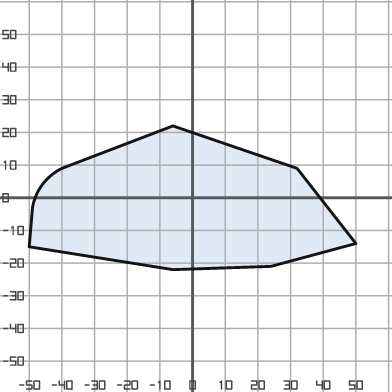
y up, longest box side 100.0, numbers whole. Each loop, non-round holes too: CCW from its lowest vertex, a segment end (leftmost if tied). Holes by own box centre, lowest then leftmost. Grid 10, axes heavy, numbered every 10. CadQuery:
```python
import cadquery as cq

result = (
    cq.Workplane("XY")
    .moveTo(-6.0, -22.0)
    .lineTo(24.0, -21.0)
    .lineTo(50.0, -14.0)
    .lineTo(32.0, 9.0)
    .lineTo(-6.0, 22.0)
    .lineTo(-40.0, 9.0)
    .threePointArc((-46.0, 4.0), (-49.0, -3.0))
    .lineTo(-50.0, -15.0)
    .close()
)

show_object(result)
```